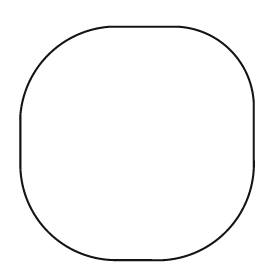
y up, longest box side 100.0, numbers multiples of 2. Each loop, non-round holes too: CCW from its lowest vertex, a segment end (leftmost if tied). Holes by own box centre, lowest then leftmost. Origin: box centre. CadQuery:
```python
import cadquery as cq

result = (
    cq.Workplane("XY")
    .moveTo(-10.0, -50.0)
    .lineTo(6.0, -50.0)
    .threePointArc((38.0, -38.0), (50.0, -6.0))
    .lineTo(50.0, 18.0)
    .threePointArc((40.0, 40.0), (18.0, 50.0))
    .lineTo(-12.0, 50.0)
    .threePointArc((-38.0, 38.0), (-50.0, 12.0))
    .lineTo(-50.0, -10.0)
    .threePointArc((-38.0, -38.0), (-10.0, -50.0))
    .close()
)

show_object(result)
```